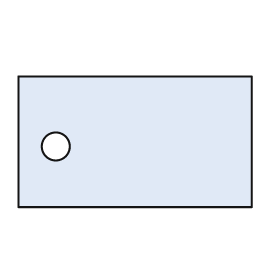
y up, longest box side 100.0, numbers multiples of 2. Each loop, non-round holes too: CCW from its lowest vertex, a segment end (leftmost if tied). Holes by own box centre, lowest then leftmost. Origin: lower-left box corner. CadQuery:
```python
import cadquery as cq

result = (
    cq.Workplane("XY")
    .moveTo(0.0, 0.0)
    .lineTo(100.0, 0.0)
    .lineTo(100.0, 56.0)
    .lineTo(0.0, 56.0)
    .close()
    .moveTo(16.0, 26.0)
    .circle(6.0)
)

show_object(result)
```